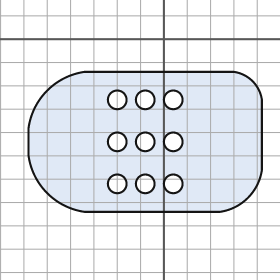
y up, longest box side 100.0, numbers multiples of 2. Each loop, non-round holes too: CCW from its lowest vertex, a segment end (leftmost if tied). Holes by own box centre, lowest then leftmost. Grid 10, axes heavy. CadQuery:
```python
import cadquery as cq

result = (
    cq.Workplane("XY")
    .moveTo(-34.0, -74.0)
    .lineTo(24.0, -74.0)
    .threePointArc((36.0, -68.0), (42.0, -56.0))
    .lineTo(42.0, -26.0)
    .threePointArc((38.0, -18.0), (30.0, -14.0))
    .lineTo(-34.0, -14.0)
    .threePointArc((-50.0, -22.0), (-58.0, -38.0))
    .lineTo(-58.0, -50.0)
    .threePointArc((-50.0, -66.0), (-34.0, -74.0))
    .close()
    .moveTo(-20.0, -62.0)
    .circle(4.0)
    .moveTo(-8.0, -62.0)
    .circle(4.0)
    .moveTo(4.0, -62.0)
    .circle(4.0)
    .moveTo(-20.0, -44.0)
    .circle(4.0)
    .moveTo(-8.0, -44.0)
    .circle(4.0)
    .moveTo(4.0, -44.0)
    .circle(4.0)
    .moveTo(-20.0, -26.0)
    .circle(4.0)
    .moveTo(-8.0, -26.0)
    .circle(4.0)
    .moveTo(4.0, -26.0)
    .circle(4.0)
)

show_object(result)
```